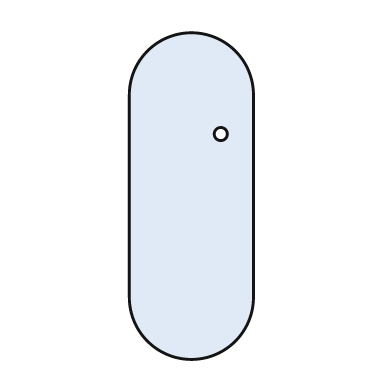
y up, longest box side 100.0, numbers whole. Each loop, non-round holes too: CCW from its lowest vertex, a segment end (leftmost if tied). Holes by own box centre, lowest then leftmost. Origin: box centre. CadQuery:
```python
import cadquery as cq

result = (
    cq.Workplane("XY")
    .moveTo(-19.0, -31.0)
    .threePointArc((0.0, -50.0), (19.0, -31.0))
    .lineTo(19.0, 31.0)
    .threePointArc((0.0, 50.0), (-19.0, 31.0))
    .close()
    .moveTo(9.0, 19.0)
    .circle(2.0)
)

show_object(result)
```